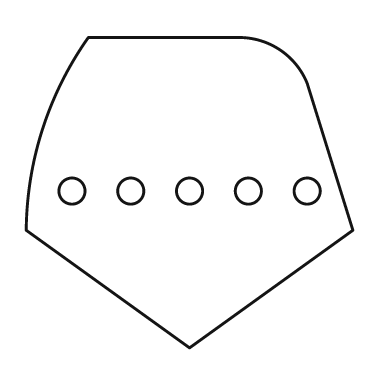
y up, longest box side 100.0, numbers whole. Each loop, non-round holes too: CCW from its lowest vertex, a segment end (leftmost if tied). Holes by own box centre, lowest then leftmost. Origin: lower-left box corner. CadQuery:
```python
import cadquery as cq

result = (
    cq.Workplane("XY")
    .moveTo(50.0, 0.0)
    .lineTo(100.0, 36.0)
    .lineTo(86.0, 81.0)
    .threePointArc((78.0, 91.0), (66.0, 95.0))
    .lineTo(19.0, 95.0)
    .threePointArc((5.0, 67.0), (0.0, 36.0))
    .close()
    .moveTo(14.0, 48.0)
    .circle(4.0)
    .moveTo(32.0, 48.0)
    .circle(4.0)
    .moveTo(50.0, 48.0)
    .circle(4.0)
    .moveTo(68.0, 48.0)
    .circle(4.0)
    .moveTo(86.0, 48.0)
    .circle(4.0)
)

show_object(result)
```